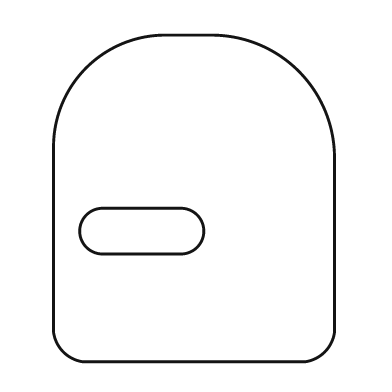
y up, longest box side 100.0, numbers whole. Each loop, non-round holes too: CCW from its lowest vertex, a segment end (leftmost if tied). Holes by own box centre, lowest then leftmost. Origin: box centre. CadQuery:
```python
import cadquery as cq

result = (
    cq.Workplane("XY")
    .moveTo(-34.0, -50.0)
    .lineTo(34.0, -50.0)
    .threePointArc((40.0, -47.0), (43.0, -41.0))
    .lineTo(43.0, 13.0)
    .threePointArc((32.0, 39.0), (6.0, 50.0))
    .lineTo(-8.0, 50.0)
    .threePointArc((-33.0, 40.0), (-43.0, 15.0))
    .lineTo(-43.0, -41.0)
    .threePointArc((-40.0, -47.0), (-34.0, -50.0))
    .close()
    .moveTo(-28.0, -17.0)
    .lineTo(-4.0, -17.0)
    .threePointArc((3.0, -10.0), (-4.0, -3.0))
    .lineTo(-28.0, -3.0)
    .threePointArc((-35.0, -10.0), (-28.0, -17.0))
    .close()
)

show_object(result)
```